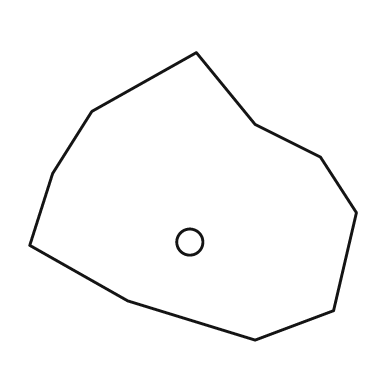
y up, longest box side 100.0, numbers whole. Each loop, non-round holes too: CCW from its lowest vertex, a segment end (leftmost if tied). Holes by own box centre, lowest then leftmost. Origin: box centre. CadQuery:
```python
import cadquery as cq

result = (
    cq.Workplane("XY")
    .moveTo(19.0, -44.0)
    .lineTo(43.0, -35.0)
    .lineTo(50.0, -5.0)
    .lineTo(39.0, 12.0)
    .lineTo(19.0, 22.0)
    .lineTo(1.0, 44.0)
    .lineTo(-31.0, 26.0)
    .lineTo(-43.0, 7.0)
    .lineTo(-50.0, -15.0)
    .lineTo(-20.0, -32.0)
    .close()
    .moveTo(-1.0, -14.0)
    .circle(4.0)
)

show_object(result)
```